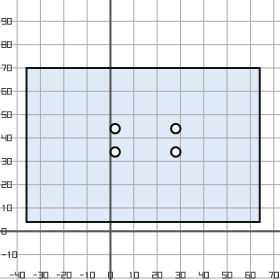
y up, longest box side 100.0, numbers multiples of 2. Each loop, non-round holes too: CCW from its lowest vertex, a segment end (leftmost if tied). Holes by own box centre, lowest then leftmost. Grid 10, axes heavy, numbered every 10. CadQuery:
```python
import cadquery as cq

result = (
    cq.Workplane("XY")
    .moveTo(-36.0, 4.0)
    .lineTo(64.0, 4.0)
    .lineTo(64.0, 70.0)
    .lineTo(-36.0, 70.0)
    .close()
    .moveTo(2.0, 34.0)
    .circle(2.0)
    .moveTo(28.0, 34.0)
    .circle(2.0)
    .moveTo(2.0, 44.0)
    .circle(2.0)
    .moveTo(28.0, 44.0)
    .circle(2.0)
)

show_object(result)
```